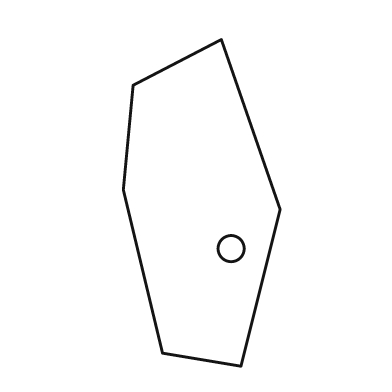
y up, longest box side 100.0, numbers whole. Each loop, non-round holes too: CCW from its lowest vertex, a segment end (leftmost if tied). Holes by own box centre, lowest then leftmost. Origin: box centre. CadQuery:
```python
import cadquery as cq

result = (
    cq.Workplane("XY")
    .moveTo(12.0, -50.0)
    .lineTo(24.0, -2.0)
    .lineTo(6.0, 50.0)
    .lineTo(-21.0, 36.0)
    .lineTo(-24.0, 4.0)
    .lineTo(-12.0, -46.0)
    .close()
    .moveTo(9.0, -14.0)
    .circle(4.0)
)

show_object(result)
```